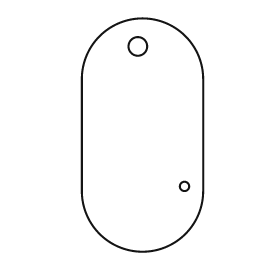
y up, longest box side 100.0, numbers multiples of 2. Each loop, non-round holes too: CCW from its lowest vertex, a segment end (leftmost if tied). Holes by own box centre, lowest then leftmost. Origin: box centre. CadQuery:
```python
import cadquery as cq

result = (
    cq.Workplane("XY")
    .moveTo(-26.0, -24.0)
    .threePointArc((0.0, -50.0), (26.0, -24.0))
    .lineTo(26.0, 24.0)
    .threePointArc((0.0, 50.0), (-26.0, 24.0))
    .close()
    .moveTo(18.0, -22.0)
    .circle(2.0)
    .moveTo(-2.0, 38.0)
    .circle(4.0)
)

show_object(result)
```